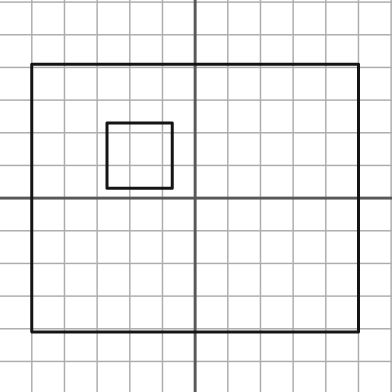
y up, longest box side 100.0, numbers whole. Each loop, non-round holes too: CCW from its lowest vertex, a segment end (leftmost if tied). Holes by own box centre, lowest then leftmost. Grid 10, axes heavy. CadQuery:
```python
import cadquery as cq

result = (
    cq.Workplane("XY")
    .moveTo(-50.0, -41.0)
    .lineTo(50.0, -41.0)
    .lineTo(50.0, 41.0)
    .lineTo(-50.0, 41.0)
    .close()
    .moveTo(-27.0, 3.0)
    .lineTo(-7.0, 3.0)
    .lineTo(-7.0, 23.0)
    .lineTo(-27.0, 23.0)
    .close()
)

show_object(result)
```